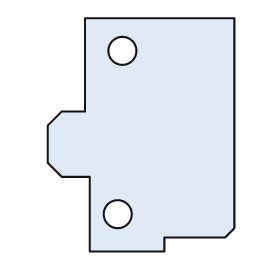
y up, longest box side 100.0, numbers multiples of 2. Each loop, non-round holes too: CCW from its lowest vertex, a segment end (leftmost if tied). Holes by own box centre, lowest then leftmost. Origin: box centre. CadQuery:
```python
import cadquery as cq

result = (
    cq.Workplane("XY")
    .moveTo(-22.0, -50.0)
    .lineTo(10.0, -50.0)
    .lineTo(10.0, -44.0)
    .lineTo(36.0, -44.0)
    .lineTo(40.0, -40.0)
    .lineTo(40.0, 50.0)
    .lineTo(-24.0, 50.0)
    .lineTo(-24.0, 10.0)
    .lineTo(-34.0, 10.0)
    .lineTo(-40.0, 4.0)
    .lineTo(-40.0, -12.0)
    .lineTo(-34.0, -18.0)
    .lineTo(-22.0, -18.0)
    .close()
    .moveTo(-10.0, -34.0)
    .circle(6.0)
    .moveTo(-8.0, 36.0)
    .circle(6.0)
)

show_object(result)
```